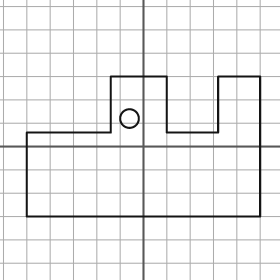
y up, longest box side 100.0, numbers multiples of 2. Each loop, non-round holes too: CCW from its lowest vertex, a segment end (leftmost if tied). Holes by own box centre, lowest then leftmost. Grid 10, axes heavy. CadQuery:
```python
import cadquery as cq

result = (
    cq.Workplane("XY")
    .moveTo(-50.0, -30.0)
    .lineTo(50.0, -30.0)
    .lineTo(50.0, 30.0)
    .lineTo(32.0, 30.0)
    .lineTo(32.0, 6.0)
    .lineTo(10.0, 6.0)
    .lineTo(10.0, 30.0)
    .lineTo(-14.0, 30.0)
    .lineTo(-14.0, 6.0)
    .lineTo(-50.0, 6.0)
    .close()
    .moveTo(-6.0, 12.0)
    .circle(4.0)
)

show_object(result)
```